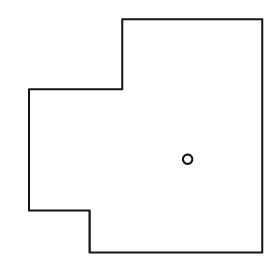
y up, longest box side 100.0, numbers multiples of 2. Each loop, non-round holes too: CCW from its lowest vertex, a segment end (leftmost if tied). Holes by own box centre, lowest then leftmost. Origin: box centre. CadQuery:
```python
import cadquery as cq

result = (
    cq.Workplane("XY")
    .moveTo(-24.0, -50.0)
    .lineTo(50.0, -50.0)
    .lineTo(50.0, 50.0)
    .lineTo(-10.0, 50.0)
    .lineTo(-10.0, 20.0)
    .lineTo(-50.0, 20.0)
    .lineTo(-50.0, -32.0)
    .lineTo(-24.0, -32.0)
    .close()
    .moveTo(18.0, -10.0)
    .circle(2.0)
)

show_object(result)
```